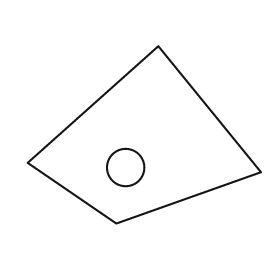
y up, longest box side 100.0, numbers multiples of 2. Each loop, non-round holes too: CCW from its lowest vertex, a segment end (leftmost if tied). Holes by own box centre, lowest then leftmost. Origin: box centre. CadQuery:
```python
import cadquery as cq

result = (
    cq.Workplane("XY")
    .moveTo(-12.0, -38.0)
    .lineTo(50.0, -16.0)
    .lineTo(6.0, 38.0)
    .lineTo(-50.0, -12.0)
    .close()
    .moveTo(-8.0, -14.0)
    .circle(8.0)
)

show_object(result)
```